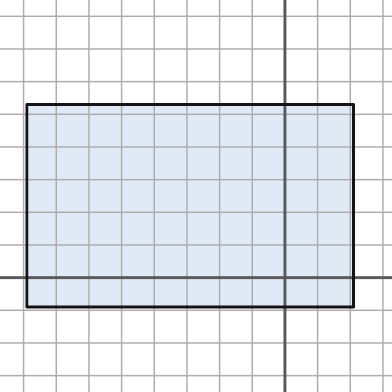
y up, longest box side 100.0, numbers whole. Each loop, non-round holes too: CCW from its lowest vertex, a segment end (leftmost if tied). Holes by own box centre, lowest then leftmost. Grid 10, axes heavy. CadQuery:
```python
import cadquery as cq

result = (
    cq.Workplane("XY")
    .moveTo(-79.0, -9.0)
    .lineTo(21.0, -9.0)
    .lineTo(21.0, 53.0)
    .lineTo(-79.0, 53.0)
    .close()
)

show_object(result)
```